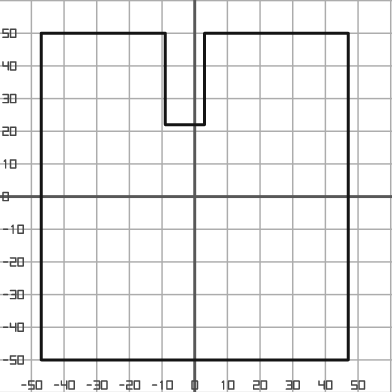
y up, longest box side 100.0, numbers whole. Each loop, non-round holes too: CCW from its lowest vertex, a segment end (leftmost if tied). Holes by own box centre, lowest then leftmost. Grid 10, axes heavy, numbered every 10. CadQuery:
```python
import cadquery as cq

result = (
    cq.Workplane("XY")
    .moveTo(-47.0, -50.0)
    .lineTo(47.0, -50.0)
    .lineTo(47.0, 50.0)
    .lineTo(3.0, 50.0)
    .lineTo(3.0, 22.0)
    .lineTo(-9.0, 22.0)
    .lineTo(-9.0, 50.0)
    .lineTo(-47.0, 50.0)
    .close()
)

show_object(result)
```